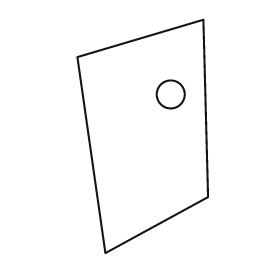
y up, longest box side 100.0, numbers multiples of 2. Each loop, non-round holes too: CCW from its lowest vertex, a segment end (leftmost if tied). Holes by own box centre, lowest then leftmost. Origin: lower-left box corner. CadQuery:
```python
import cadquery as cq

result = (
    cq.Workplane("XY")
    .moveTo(12.0, 0.0)
    .lineTo(56.0, 24.0)
    .lineTo(54.0, 100.0)
    .lineTo(0.0, 84.0)
    .close()
    .moveTo(40.0, 68.0)
    .circle(6.0)
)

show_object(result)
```